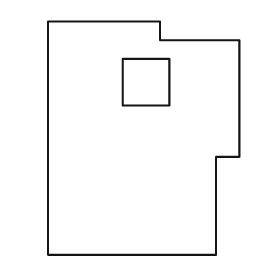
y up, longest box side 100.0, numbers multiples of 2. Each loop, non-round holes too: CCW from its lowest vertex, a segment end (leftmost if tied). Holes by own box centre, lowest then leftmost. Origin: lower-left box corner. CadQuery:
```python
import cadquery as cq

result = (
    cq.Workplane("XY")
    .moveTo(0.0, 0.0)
    .lineTo(72.0, 0.0)
    .lineTo(72.0, 42.0)
    .lineTo(82.0, 42.0)
    .lineTo(82.0, 92.0)
    .lineTo(48.0, 92.0)
    .lineTo(48.0, 100.0)
    .lineTo(0.0, 100.0)
    .close()
    .moveTo(32.0, 64.0)
    .lineTo(52.0, 64.0)
    .lineTo(52.0, 84.0)
    .lineTo(32.0, 84.0)
    .close()
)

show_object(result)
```